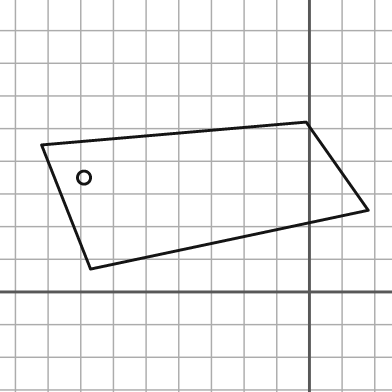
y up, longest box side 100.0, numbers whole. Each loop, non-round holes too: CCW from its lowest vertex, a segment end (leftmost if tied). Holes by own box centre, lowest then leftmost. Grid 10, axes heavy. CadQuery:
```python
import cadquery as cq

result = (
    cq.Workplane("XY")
    .moveTo(-67.0, 7.0)
    .lineTo(18.0, 25.0)
    .lineTo(-1.0, 52.0)
    .lineTo(-82.0, 45.0)
    .close()
    .moveTo(-69.0, 35.0)
    .circle(2.0)
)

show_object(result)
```